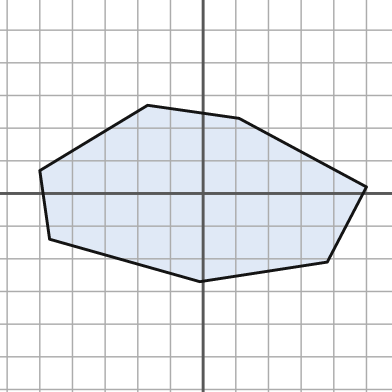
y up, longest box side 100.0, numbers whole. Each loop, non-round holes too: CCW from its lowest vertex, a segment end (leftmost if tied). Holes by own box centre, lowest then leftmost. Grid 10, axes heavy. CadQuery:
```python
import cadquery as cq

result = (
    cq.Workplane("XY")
    .moveTo(-1.0, -27.0)
    .lineTo(38.0, -21.0)
    .lineTo(50.0, 2.0)
    .lineTo(11.0, 23.0)
    .lineTo(-17.0, 27.0)
    .lineTo(-50.0, 7.0)
    .lineTo(-47.0, -14.0)
    .close()
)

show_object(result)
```